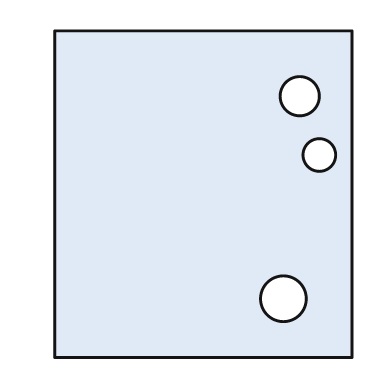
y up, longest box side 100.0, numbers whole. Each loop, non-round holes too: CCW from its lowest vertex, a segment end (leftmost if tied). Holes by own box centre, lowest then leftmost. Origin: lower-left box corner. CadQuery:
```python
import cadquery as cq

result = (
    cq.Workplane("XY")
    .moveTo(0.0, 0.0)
    .lineTo(91.0, 0.0)
    .lineTo(91.0, 100.0)
    .lineTo(0.0, 100.0)
    .close()
    .moveTo(70.0, 18.0)
    .circle(7.0)
    .moveTo(81.0, 62.0)
    .circle(5.0)
    .moveTo(75.0, 80.0)
    .circle(6.0)
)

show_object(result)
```